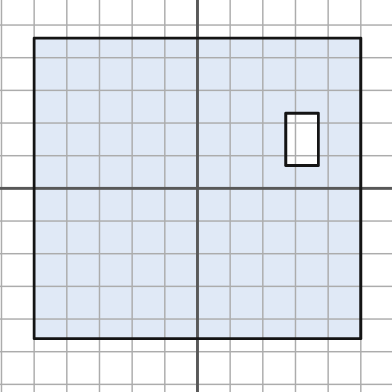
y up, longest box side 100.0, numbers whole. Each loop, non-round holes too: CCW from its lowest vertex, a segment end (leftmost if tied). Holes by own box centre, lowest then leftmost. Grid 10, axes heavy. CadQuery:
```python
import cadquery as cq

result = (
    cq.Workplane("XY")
    .moveTo(-50.0, -46.0)
    .lineTo(50.0, -46.0)
    .lineTo(50.0, 46.0)
    .lineTo(-50.0, 46.0)
    .close()
    .moveTo(27.0, 7.0)
    .lineTo(37.0, 7.0)
    .lineTo(37.0, 23.0)
    .lineTo(27.0, 23.0)
    .close()
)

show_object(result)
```